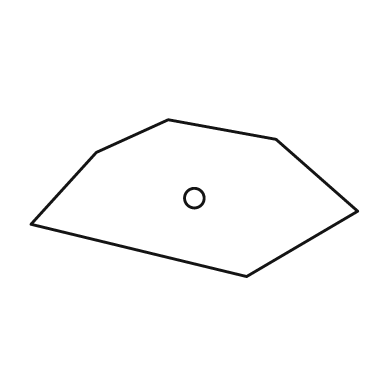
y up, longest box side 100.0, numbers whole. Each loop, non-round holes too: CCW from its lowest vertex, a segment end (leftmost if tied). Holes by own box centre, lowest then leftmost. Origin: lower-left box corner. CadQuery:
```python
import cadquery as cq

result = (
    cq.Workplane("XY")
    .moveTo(66.0, 0.0)
    .lineTo(100.0, 20.0)
    .lineTo(75.0, 42.0)
    .lineTo(42.0, 48.0)
    .lineTo(20.0, 38.0)
    .lineTo(0.0, 16.0)
    .close()
    .moveTo(50.0, 24.0)
    .circle(3.0)
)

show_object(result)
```